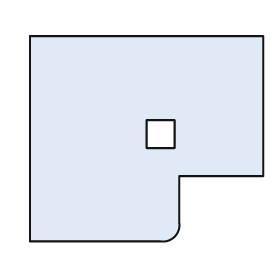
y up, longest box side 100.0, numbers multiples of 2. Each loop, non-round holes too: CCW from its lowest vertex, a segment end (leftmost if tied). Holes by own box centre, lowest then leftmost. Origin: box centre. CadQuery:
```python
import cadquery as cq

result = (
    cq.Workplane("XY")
    .moveTo(-50.0, -44.0)
    .lineTo(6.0, -44.0)
    .threePointArc((12.0, -42.0), (14.0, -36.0))
    .lineTo(14.0, -16.0)
    .lineTo(50.0, -16.0)
    .lineTo(50.0, 44.0)
    .lineTo(-50.0, 44.0)
    .close()
    .moveTo(0.0, -4.0)
    .lineTo(12.0, -4.0)
    .lineTo(12.0, 8.0)
    .lineTo(0.0, 8.0)
    .close()
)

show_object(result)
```